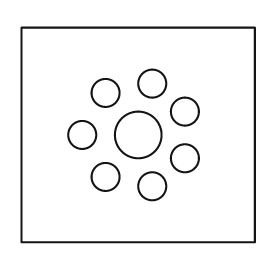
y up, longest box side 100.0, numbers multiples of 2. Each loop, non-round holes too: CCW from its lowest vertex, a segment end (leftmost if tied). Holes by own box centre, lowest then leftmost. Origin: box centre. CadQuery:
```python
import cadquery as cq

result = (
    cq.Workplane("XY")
    .moveTo(-50.0, -46.0)
    .lineTo(50.0, -46.0)
    .lineTo(50.0, 46.0)
    .lineTo(-50.0, 46.0)
    .close()
    .moveTo(6.0, -22.0)
    .circle(6.0)
    .moveTo(-14.0, -18.0)
    .circle(6.0)
    .moveTo(20.0, -10.0)
    .circle(6.0)
    .moveTo(-24.0, 0.0)
    .circle(6.0)
    .moveTo(0.0, 0.0)
    .circle(10.0)
    .moveTo(20.0, 10.0)
    .circle(6.0)
    .moveTo(-14.0, 18.0)
    .circle(6.0)
    .moveTo(6.0, 22.0)
    .circle(6.0)
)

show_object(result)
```